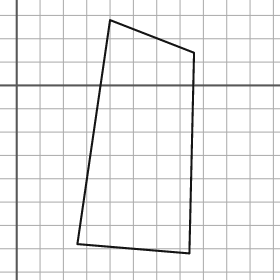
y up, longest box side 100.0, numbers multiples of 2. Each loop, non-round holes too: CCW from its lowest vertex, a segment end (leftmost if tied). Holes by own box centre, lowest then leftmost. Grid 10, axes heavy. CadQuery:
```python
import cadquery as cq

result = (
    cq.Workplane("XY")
    .moveTo(74.0, -72.0)
    .lineTo(76.0, 14.0)
    .lineTo(40.0, 28.0)
    .lineTo(26.0, -68.0)
    .close()
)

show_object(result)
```